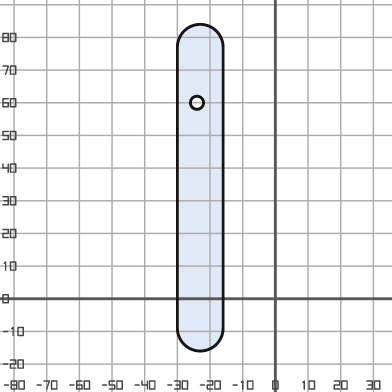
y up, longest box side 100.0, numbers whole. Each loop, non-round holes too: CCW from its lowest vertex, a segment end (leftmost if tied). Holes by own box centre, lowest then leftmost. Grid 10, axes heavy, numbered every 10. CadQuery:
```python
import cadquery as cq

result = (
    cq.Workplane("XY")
    .moveTo(-30.0, -9.0)
    .threePointArc((-23.0, -16.0), (-16.0, -9.0))
    .lineTo(-16.0, 77.0)
    .threePointArc((-23.0, 84.0), (-30.0, 77.0))
    .close()
    .moveTo(-24.0, 60.0)
    .circle(2.0)
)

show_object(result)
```